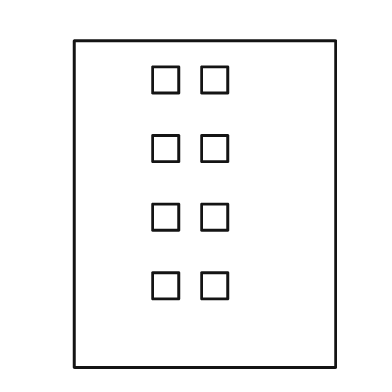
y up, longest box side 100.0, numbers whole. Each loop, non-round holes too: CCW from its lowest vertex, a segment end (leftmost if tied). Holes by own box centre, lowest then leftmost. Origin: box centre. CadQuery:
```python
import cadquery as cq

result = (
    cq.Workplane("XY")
    .moveTo(-40.0, -50.0)
    .lineTo(40.0, -50.0)
    .lineTo(40.0, 50.0)
    .lineTo(-40.0, 50.0)
    .close()
    .moveTo(-16.0, -29.0)
    .lineTo(-8.0, -29.0)
    .lineTo(-8.0, -21.0)
    .lineTo(-16.0, -21.0)
    .close()
    .moveTo(-1.0, -29.0)
    .lineTo(7.0, -29.0)
    .lineTo(7.0, -21.0)
    .lineTo(-1.0, -21.0)
    .close()
    .moveTo(-16.0, -8.0)
    .lineTo(-8.0, -8.0)
    .lineTo(-8.0, 0.0)
    .lineTo(-16.0, 0.0)
    .close()
    .moveTo(-1.0, -8.0)
    .lineTo(7.0, -8.0)
    .lineTo(7.0, 0.0)
    .lineTo(-1.0, 0.0)
    .close()
    .moveTo(-16.0, 13.0)
    .lineTo(-8.0, 13.0)
    .lineTo(-8.0, 21.0)
    .lineTo(-16.0, 21.0)
    .close()
    .moveTo(-1.0, 13.0)
    .lineTo(7.0, 13.0)
    .lineTo(7.0, 21.0)
    .lineTo(-1.0, 21.0)
    .close()
    .moveTo(-16.0, 34.0)
    .lineTo(-8.0, 34.0)
    .lineTo(-8.0, 42.0)
    .lineTo(-16.0, 42.0)
    .close()
    .moveTo(-1.0, 34.0)
    .lineTo(7.0, 34.0)
    .lineTo(7.0, 42.0)
    .lineTo(-1.0, 42.0)
    .close()
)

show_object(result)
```